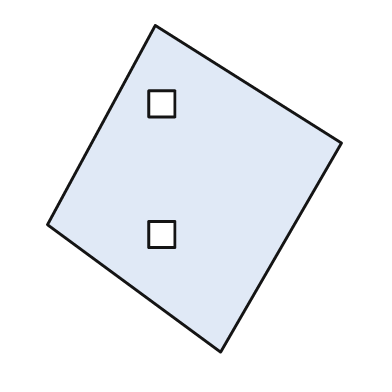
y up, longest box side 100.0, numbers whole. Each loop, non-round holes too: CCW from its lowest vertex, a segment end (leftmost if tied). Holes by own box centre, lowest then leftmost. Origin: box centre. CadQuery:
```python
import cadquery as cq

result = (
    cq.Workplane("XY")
    .moveTo(8.0, -50.0)
    .lineTo(45.0, 14.0)
    .lineTo(-12.0, 50.0)
    .lineTo(-45.0, -11.0)
    .close()
    .moveTo(-14.0, -18.0)
    .lineTo(-6.0, -18.0)
    .lineTo(-6.0, -10.0)
    .lineTo(-14.0, -10.0)
    .close()
    .moveTo(-14.0, 22.0)
    .lineTo(-6.0, 22.0)
    .lineTo(-6.0, 30.0)
    .lineTo(-14.0, 30.0)
    .close()
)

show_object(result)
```